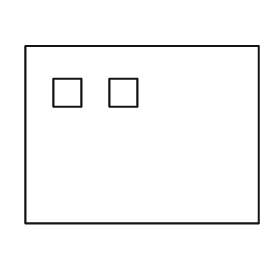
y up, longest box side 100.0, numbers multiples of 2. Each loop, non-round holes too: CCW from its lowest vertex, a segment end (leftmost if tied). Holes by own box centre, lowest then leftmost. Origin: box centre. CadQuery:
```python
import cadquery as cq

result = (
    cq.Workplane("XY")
    .moveTo(-50.0, -38.0)
    .lineTo(50.0, -38.0)
    .lineTo(50.0, 38.0)
    .lineTo(-50.0, 38.0)
    .close()
    .moveTo(-38.0, 12.0)
    .lineTo(-26.0, 12.0)
    .lineTo(-26.0, 24.0)
    .lineTo(-38.0, 24.0)
    .close()
    .moveTo(-14.0, 12.0)
    .lineTo(-2.0, 12.0)
    .lineTo(-2.0, 24.0)
    .lineTo(-14.0, 24.0)
    .close()
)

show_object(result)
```